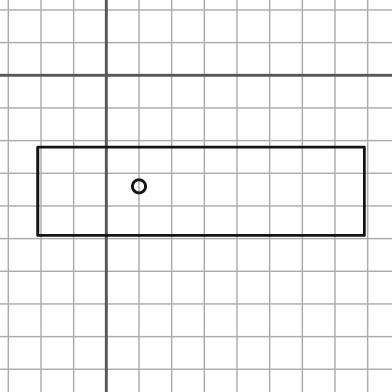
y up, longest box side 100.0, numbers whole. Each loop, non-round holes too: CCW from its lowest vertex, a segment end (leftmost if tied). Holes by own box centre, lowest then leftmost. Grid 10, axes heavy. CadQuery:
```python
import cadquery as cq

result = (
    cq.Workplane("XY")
    .moveTo(-21.0, -49.0)
    .lineTo(79.0, -49.0)
    .lineTo(79.0, -22.0)
    .lineTo(-21.0, -22.0)
    .close()
    .moveTo(10.0, -34.0)
    .circle(2.0)
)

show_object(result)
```